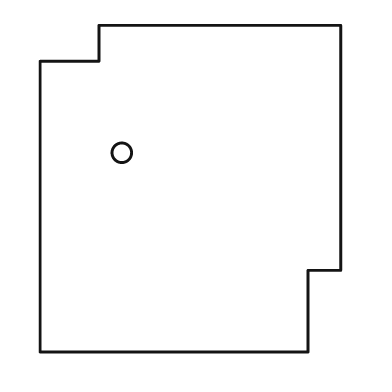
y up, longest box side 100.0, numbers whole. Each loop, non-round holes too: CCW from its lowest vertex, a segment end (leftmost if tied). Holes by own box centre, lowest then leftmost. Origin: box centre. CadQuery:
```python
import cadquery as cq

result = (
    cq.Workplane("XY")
    .moveTo(-46.0, -50.0)
    .lineTo(36.0, -50.0)
    .lineTo(36.0, -25.0)
    .lineTo(46.0, -25.0)
    .lineTo(46.0, 50.0)
    .lineTo(-28.0, 50.0)
    .lineTo(-28.0, 39.0)
    .lineTo(-46.0, 39.0)
    .close()
    .moveTo(-21.0, 11.0)
    .circle(3.0)
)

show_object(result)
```